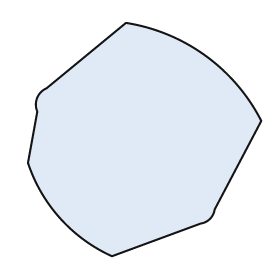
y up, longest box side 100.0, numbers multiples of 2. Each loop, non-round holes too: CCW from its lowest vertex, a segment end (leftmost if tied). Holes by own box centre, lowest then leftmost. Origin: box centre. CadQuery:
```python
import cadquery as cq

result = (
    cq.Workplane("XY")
    .moveTo(-14.0, -50.0)
    .lineTo(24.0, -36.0)
    .threePointArc((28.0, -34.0), (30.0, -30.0))
    .lineTo(50.0, 8.0)
    .threePointArc((26.0, 36.0), (-8.0, 50.0))
    .lineTo(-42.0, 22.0)
    .threePointArc((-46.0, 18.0), (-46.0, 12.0))
    .lineTo(-50.0, -10.0)
    .threePointArc((-36.0, -34.0), (-14.0, -50.0))
    .close()
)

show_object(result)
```